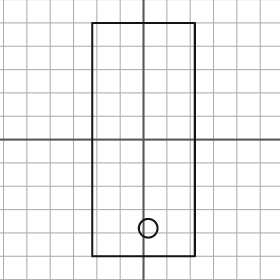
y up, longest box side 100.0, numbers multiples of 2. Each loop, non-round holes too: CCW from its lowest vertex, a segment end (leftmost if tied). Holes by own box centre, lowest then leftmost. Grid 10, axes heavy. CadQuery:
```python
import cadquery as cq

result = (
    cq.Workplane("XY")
    .moveTo(-22.0, -50.0)
    .lineTo(22.0, -50.0)
    .lineTo(22.0, 50.0)
    .lineTo(-22.0, 50.0)
    .close()
    .moveTo(2.0, -38.0)
    .circle(4.0)
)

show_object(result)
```